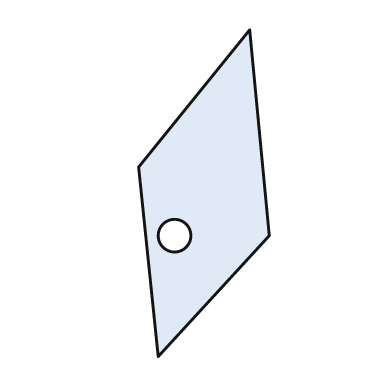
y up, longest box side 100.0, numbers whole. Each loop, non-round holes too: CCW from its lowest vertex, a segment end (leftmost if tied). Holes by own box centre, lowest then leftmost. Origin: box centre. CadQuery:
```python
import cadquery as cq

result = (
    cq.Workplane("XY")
    .moveTo(-14.0, -50.0)
    .lineTo(20.0, -13.0)
    .lineTo(14.0, 50.0)
    .lineTo(-20.0, 8.0)
    .close()
    .moveTo(-9.0, -13.0)
    .circle(5.0)
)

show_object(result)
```